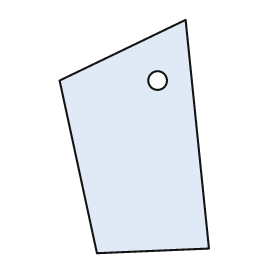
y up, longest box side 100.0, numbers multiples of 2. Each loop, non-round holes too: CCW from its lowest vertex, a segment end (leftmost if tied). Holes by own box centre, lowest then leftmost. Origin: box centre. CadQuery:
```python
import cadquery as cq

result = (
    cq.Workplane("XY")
    .moveTo(-16.0, -50.0)
    .lineTo(32.0, -48.0)
    .lineTo(22.0, 50.0)
    .lineTo(-32.0, 24.0)
    .close()
    .moveTo(10.0, 24.0)
    .circle(4.0)
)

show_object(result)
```